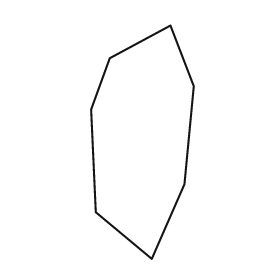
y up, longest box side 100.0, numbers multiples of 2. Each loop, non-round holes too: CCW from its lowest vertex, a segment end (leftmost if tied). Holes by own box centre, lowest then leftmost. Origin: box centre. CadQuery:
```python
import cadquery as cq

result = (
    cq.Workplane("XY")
    .moveTo(4.0, -50.0)
    .lineTo(18.0, -18.0)
    .lineTo(22.0, 24.0)
    .lineTo(12.0, 50.0)
    .lineTo(-14.0, 36.0)
    .lineTo(-22.0, 14.0)
    .lineTo(-20.0, -30.0)
    .close()
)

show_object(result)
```